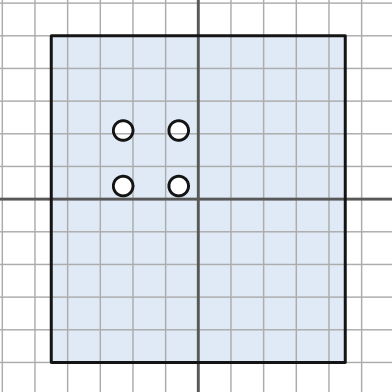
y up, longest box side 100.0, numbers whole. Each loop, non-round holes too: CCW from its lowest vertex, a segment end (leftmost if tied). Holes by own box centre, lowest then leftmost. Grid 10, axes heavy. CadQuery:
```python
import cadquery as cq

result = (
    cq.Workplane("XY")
    .moveTo(-45.0, -50.0)
    .lineTo(45.0, -50.0)
    .lineTo(45.0, 50.0)
    .lineTo(-45.0, 50.0)
    .close()
    .moveTo(-23.0, 4.0)
    .circle(3.0)
    .moveTo(-6.0, 4.0)
    .circle(3.0)
    .moveTo(-23.0, 21.0)
    .circle(3.0)
    .moveTo(-6.0, 21.0)
    .circle(3.0)
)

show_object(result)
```